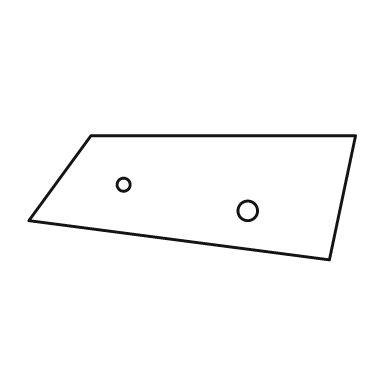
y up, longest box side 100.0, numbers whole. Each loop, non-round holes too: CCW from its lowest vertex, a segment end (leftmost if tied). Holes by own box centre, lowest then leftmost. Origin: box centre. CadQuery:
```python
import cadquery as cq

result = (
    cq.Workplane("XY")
    .moveTo(42.0, -19.0)
    .lineTo(50.0, 19.0)
    .lineTo(-31.0, 19.0)
    .lineTo(-50.0, -7.0)
    .close()
    .moveTo(17.0, -4.0)
    .circle(3.0)
    .moveTo(-21.0, 4.0)
    .circle(2.0)
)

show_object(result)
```